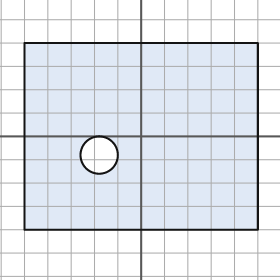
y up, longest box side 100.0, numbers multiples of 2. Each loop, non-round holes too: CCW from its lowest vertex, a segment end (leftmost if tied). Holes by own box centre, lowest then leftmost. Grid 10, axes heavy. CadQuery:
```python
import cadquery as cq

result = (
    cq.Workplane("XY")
    .moveTo(-50.0, -40.0)
    .lineTo(50.0, -40.0)
    .lineTo(50.0, 40.0)
    .lineTo(-50.0, 40.0)
    .close()
    .moveTo(-18.0, -8.0)
    .circle(8.0)
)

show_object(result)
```